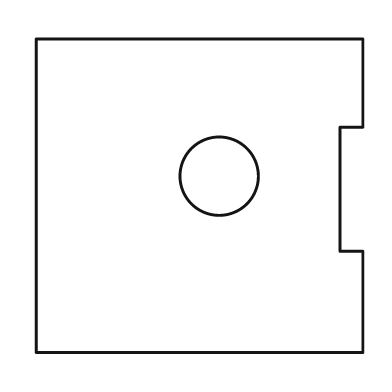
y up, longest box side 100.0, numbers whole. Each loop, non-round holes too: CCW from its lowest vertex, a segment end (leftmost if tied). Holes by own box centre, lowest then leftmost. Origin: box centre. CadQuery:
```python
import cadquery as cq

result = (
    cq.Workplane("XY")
    .moveTo(-50.0, -48.0)
    .lineTo(50.0, -48.0)
    .lineTo(50.0, -17.0)
    .lineTo(43.0, -17.0)
    .lineTo(43.0, 21.0)
    .lineTo(50.0, 21.0)
    .lineTo(50.0, 48.0)
    .lineTo(-50.0, 48.0)
    .close()
    .moveTo(6.0, 6.0)
    .circle(12.0)
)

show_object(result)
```